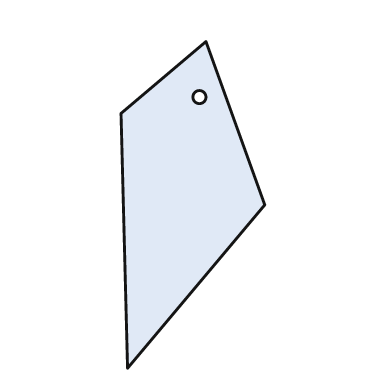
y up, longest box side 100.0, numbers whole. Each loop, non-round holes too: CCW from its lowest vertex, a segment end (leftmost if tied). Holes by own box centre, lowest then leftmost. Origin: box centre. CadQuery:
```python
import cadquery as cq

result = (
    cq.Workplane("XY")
    .moveTo(-20.0, -50.0)
    .lineTo(22.0, 0.0)
    .lineTo(4.0, 50.0)
    .lineTo(-22.0, 28.0)
    .close()
    .moveTo(2.0, 33.0)
    .circle(2.0)
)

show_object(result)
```